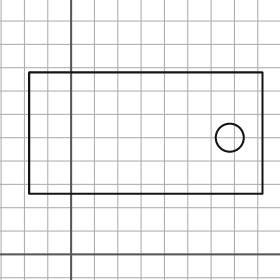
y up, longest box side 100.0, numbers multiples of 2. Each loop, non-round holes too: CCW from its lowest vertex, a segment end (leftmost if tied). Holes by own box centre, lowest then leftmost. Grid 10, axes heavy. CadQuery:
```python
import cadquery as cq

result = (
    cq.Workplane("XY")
    .moveTo(-18.0, 26.0)
    .lineTo(82.0, 26.0)
    .lineTo(82.0, 78.0)
    .lineTo(-18.0, 78.0)
    .close()
    .moveTo(68.0, 50.0)
    .circle(6.0)
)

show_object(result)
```